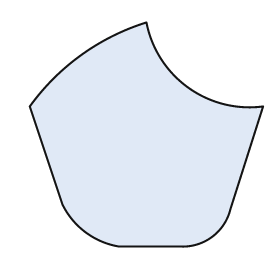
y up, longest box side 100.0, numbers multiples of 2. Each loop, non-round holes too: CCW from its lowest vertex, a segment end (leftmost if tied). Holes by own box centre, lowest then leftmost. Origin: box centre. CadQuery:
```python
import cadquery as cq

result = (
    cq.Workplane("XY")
    .moveTo(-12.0, -48.0)
    .lineTo(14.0, -48.0)
    .threePointArc((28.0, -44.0), (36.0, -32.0))
    .lineTo(50.0, 12.0)
    .threePointArc((18.0, 20.0), (0.0, 48.0))
    .threePointArc((-28.0, 34.0), (-50.0, 12.0))
    .lineTo(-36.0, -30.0)
    .threePointArc((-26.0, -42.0), (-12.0, -48.0))
    .close()
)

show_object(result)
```